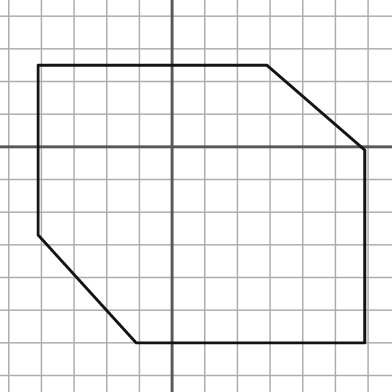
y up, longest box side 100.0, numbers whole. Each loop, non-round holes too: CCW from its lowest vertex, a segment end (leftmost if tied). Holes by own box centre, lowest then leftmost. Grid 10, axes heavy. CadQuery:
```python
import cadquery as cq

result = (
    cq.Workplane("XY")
    .moveTo(-11.0, -60.0)
    .lineTo(59.0, -60.0)
    .lineTo(59.0, -1.0)
    .lineTo(29.0, 25.0)
    .lineTo(-41.0, 25.0)
    .lineTo(-41.0, -27.0)
    .close()
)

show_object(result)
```